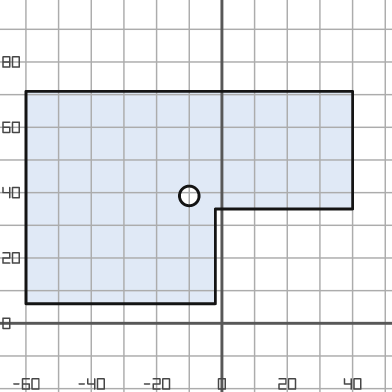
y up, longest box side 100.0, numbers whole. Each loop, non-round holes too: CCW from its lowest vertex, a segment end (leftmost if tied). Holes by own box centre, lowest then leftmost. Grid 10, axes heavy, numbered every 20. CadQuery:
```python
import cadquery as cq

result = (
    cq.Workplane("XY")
    .moveTo(-60.0, 6.0)
    .lineTo(-2.0, 6.0)
    .lineTo(-2.0, 35.0)
    .lineTo(40.0, 35.0)
    .lineTo(40.0, 71.0)
    .lineTo(-60.0, 71.0)
    .close()
    .moveTo(-10.0, 39.0)
    .circle(3.0)
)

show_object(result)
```